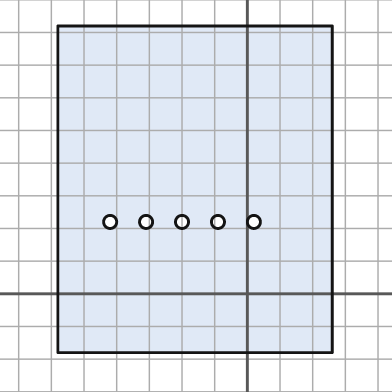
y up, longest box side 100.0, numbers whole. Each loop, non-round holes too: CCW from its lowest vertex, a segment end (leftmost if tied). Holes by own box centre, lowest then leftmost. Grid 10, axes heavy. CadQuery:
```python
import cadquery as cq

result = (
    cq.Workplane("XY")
    .moveTo(-58.0, -18.0)
    .lineTo(26.0, -18.0)
    .lineTo(26.0, 82.0)
    .lineTo(-58.0, 82.0)
    .close()
    .moveTo(-42.0, 22.0)
    .circle(2.0)
    .moveTo(-31.0, 22.0)
    .circle(2.0)
    .moveTo(-20.0, 22.0)
    .circle(2.0)
    .moveTo(-9.0, 22.0)
    .circle(2.0)
    .moveTo(2.0, 22.0)
    .circle(2.0)
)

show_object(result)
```